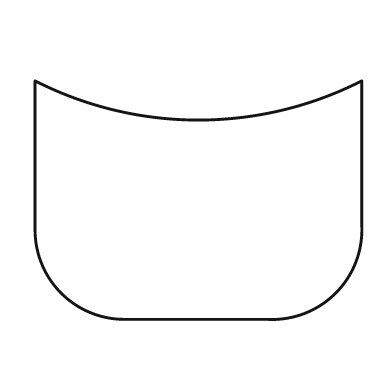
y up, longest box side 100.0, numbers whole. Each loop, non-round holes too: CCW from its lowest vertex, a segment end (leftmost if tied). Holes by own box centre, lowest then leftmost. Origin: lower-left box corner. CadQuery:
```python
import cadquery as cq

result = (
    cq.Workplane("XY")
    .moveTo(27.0, 0.0)
    .lineTo(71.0, 0.0)
    .threePointArc((92.0, 8.0), (100.0, 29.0))
    .lineTo(100.0, 73.0)
    .threePointArc((50.0, 61.0), (0.0, 73.0))
    .lineTo(0.0, 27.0)
    .threePointArc((8.0, 8.0), (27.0, 0.0))
    .close()
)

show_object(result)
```